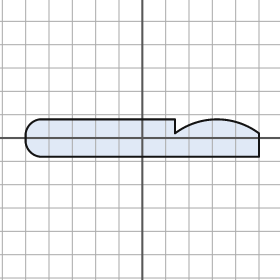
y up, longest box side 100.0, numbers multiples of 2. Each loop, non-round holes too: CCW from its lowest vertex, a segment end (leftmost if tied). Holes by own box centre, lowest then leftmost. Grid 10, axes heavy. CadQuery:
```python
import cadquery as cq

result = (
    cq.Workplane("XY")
    .moveTo(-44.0, -8.0)
    .lineTo(50.0, -8.0)
    .lineTo(50.0, 2.0)
    .threePointArc((32.0, 8.0), (14.0, 2.0))
    .lineTo(14.0, 8.0)
    .lineTo(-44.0, 8.0)
    .threePointArc((-48.0, 6.0), (-50.0, 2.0))
    .lineTo(-50.0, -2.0)
    .threePointArc((-48.0, -6.0), (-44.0, -8.0))
    .close()
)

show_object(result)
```